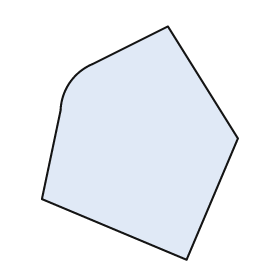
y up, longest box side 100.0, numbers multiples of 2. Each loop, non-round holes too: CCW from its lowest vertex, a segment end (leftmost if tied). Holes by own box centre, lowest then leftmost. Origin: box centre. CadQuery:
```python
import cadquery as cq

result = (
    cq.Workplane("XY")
    .moveTo(20.0, -50.0)
    .lineTo(42.0, 2.0)
    .lineTo(12.0, 50.0)
    .lineTo(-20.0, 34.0)
    .threePointArc((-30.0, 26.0), (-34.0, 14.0))
    .lineTo(-42.0, -24.0)
    .close()
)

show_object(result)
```